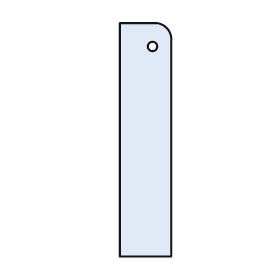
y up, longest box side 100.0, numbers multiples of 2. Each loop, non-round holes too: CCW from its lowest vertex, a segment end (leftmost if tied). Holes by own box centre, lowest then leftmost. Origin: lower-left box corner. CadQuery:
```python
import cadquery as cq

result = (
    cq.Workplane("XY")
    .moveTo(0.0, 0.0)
    .lineTo(22.0, 0.0)
    .lineTo(22.0, 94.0)
    .threePointArc((20.0, 98.0), (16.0, 100.0))
    .lineTo(0.0, 100.0)
    .close()
    .moveTo(14.0, 90.0)
    .circle(2.0)
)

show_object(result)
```